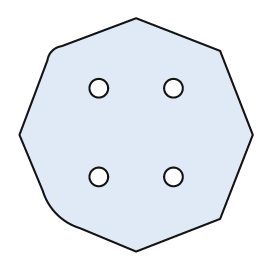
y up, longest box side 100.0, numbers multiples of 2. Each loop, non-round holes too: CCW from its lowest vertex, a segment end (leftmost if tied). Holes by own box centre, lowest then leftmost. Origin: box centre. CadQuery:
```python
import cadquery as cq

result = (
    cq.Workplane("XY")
    .moveTo(0.0, -50.0)
    .lineTo(36.0, -36.0)
    .lineTo(50.0, 0.0)
    .lineTo(36.0, 36.0)
    .lineTo(0.0, 50.0)
    .lineTo(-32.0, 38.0)
    .threePointArc((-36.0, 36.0), (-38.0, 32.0))
    .lineTo(-50.0, 0.0)
    .lineTo(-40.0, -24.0)
    .threePointArc((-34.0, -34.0), (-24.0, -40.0))
    .close()
    .moveTo(-16.0, -18.0)
    .circle(4.0)
    .moveTo(16.0, -18.0)
    .circle(4.0)
    .moveTo(-16.0, 20.0)
    .circle(4.0)
    .moveTo(16.0, 20.0)
    .circle(4.0)
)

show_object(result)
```